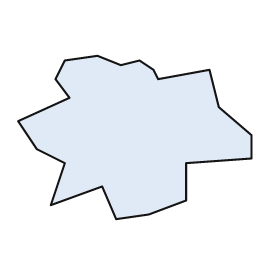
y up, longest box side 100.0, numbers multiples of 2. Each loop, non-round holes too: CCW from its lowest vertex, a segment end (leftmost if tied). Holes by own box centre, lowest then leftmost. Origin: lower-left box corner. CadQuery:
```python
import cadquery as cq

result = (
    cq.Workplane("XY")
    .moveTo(42.0, 0.0)
    .lineTo(56.0, 2.0)
    .lineTo(72.0, 8.0)
    .lineTo(72.0, 24.0)
    .lineTo(100.0, 26.0)
    .lineTo(100.0, 36.0)
    .lineTo(86.0, 48.0)
    .lineTo(82.0, 64.0)
    .lineTo(60.0, 60.0)
    .lineTo(58.0, 64.0)
    .lineTo(52.0, 68.0)
    .lineTo(44.0, 66.0)
    .lineTo(34.0, 70.0)
    .lineTo(20.0, 68.0)
    .lineTo(16.0, 60.0)
    .lineTo(22.0, 52.0)
    .lineTo(0.0, 42.0)
    .lineTo(8.0, 30.0)
    .lineTo(20.0, 24.0)
    .lineTo(14.0, 6.0)
    .lineTo(36.0, 14.0)
    .close()
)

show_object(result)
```